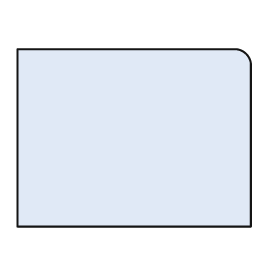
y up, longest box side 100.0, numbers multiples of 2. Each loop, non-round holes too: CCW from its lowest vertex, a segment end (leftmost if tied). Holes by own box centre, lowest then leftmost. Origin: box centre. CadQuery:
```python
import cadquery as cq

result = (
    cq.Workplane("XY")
    .moveTo(-50.0, -38.0)
    .lineTo(50.0, -38.0)
    .lineTo(50.0, 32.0)
    .threePointArc((48.0, 36.0), (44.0, 38.0))
    .lineTo(-50.0, 38.0)
    .close()
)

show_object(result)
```